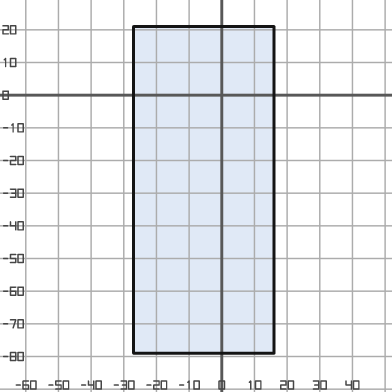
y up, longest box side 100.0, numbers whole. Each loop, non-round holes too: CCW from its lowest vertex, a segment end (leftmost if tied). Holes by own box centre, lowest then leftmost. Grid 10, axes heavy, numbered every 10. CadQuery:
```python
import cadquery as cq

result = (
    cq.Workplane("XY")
    .moveTo(-27.0, -79.0)
    .lineTo(16.0, -79.0)
    .lineTo(16.0, 21.0)
    .lineTo(-27.0, 21.0)
    .close()
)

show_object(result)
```